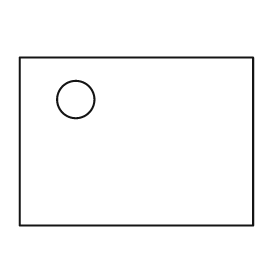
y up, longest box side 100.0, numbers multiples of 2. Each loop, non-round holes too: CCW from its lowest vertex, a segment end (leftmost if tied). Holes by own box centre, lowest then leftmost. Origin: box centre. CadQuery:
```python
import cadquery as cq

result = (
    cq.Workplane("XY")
    .moveTo(-50.0, -36.0)
    .lineTo(50.0, -36.0)
    .lineTo(50.0, 36.0)
    .lineTo(-50.0, 36.0)
    .close()
    .moveTo(-26.0, 18.0)
    .circle(8.0)
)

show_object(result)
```